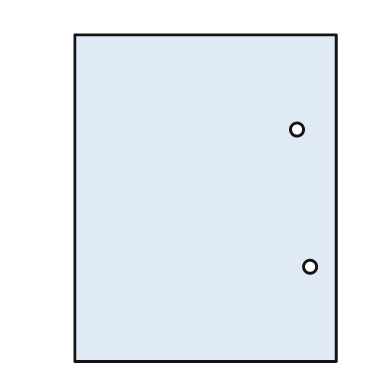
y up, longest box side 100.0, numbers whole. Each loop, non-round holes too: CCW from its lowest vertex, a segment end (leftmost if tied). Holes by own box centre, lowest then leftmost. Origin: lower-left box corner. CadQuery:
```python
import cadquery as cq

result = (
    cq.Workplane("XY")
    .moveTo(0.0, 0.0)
    .lineTo(80.0, 0.0)
    .lineTo(80.0, 100.0)
    .lineTo(0.0, 100.0)
    .close()
    .moveTo(72.0, 29.0)
    .circle(2.0)
    .moveTo(68.0, 71.0)
    .circle(2.0)
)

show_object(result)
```